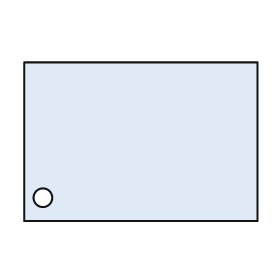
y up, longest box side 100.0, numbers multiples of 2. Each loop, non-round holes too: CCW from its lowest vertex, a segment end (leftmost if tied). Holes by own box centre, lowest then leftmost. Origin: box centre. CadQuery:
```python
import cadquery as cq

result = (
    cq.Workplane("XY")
    .moveTo(-50.0, -34.0)
    .lineTo(50.0, -34.0)
    .lineTo(50.0, 34.0)
    .lineTo(-50.0, 34.0)
    .close()
    .moveTo(-42.0, -24.0)
    .circle(4.0)
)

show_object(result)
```